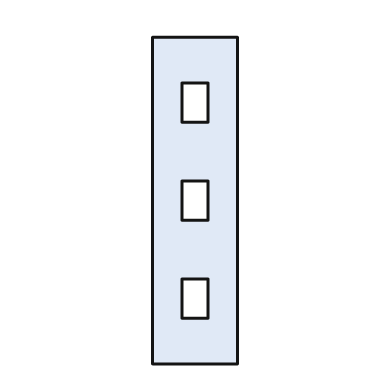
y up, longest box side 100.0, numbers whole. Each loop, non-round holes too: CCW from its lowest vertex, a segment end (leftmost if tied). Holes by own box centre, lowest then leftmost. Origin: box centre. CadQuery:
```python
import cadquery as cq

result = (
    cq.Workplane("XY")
    .moveTo(-13.0, -50.0)
    .lineTo(13.0, -50.0)
    .lineTo(13.0, 50.0)
    .lineTo(-13.0, 50.0)
    .close()
    .moveTo(-4.0, -36.0)
    .lineTo(4.0, -36.0)
    .lineTo(4.0, -24.0)
    .lineTo(-4.0, -24.0)
    .close()
    .moveTo(-4.0, -6.0)
    .lineTo(4.0, -6.0)
    .lineTo(4.0, 6.0)
    .lineTo(-4.0, 6.0)
    .close()
    .moveTo(-4.0, 24.0)
    .lineTo(4.0, 24.0)
    .lineTo(4.0, 36.0)
    .lineTo(-4.0, 36.0)
    .close()
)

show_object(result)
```